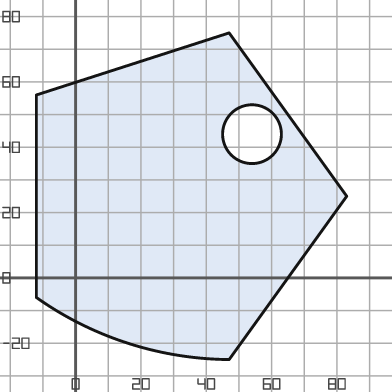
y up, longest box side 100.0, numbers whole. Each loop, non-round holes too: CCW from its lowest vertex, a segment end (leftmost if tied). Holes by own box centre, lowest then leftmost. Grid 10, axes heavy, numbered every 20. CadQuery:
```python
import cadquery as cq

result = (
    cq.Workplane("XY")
    .moveTo(47.0, -25.0)
    .lineTo(83.0, 25.0)
    .lineTo(47.0, 75.0)
    .lineTo(-12.0, 56.0)
    .lineTo(-12.0, -6.0)
    .threePointArc((16.0, -20.0), (47.0, -25.0))
    .close()
    .moveTo(54.0, 44.0)
    .circle(9.0)
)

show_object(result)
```